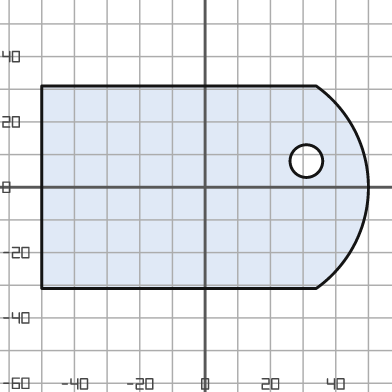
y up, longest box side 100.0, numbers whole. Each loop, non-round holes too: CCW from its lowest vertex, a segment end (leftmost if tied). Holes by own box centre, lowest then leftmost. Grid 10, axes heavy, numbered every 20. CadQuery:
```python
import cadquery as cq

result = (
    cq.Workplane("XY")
    .moveTo(-50.0, -31.0)
    .lineTo(34.0, -31.0)
    .threePointArc((50.0, 0.0), (34.0, 31.0))
    .lineTo(-50.0, 31.0)
    .close()
    .moveTo(31.0, 8.0)
    .circle(5.0)
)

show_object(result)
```